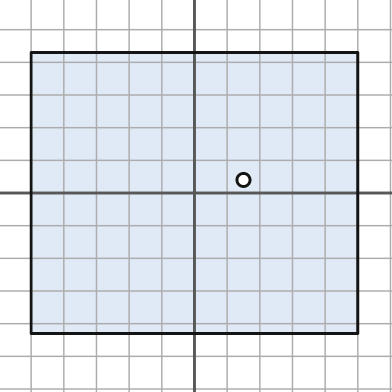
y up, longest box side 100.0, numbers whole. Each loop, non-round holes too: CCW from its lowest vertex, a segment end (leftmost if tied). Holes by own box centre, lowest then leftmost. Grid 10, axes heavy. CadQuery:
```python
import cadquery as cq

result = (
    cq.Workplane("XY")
    .moveTo(-50.0, -43.0)
    .lineTo(50.0, -43.0)
    .lineTo(50.0, 43.0)
    .lineTo(-50.0, 43.0)
    .close()
    .moveTo(15.0, 4.0)
    .circle(2.0)
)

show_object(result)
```